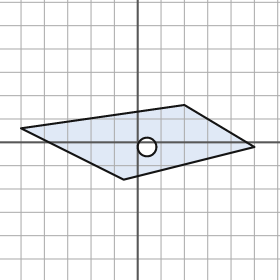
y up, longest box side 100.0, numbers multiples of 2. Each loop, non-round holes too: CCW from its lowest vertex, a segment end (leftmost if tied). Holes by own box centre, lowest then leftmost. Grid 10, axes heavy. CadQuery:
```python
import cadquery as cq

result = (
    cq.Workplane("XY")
    .moveTo(-6.0, -16.0)
    .lineTo(50.0, -2.0)
    .lineTo(20.0, 16.0)
    .lineTo(-50.0, 6.0)
    .close()
    .moveTo(4.0, -2.0)
    .circle(4.0)
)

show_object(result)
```